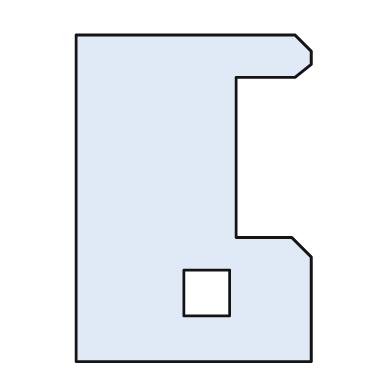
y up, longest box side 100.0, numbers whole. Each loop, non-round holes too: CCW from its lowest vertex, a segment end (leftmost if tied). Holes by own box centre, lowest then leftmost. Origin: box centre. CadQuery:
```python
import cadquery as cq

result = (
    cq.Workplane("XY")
    .moveTo(-36.0, -50.0)
    .lineTo(36.0, -50.0)
    .lineTo(36.0, -18.0)
    .lineTo(30.0, -12.0)
    .lineTo(13.0, -12.0)
    .lineTo(13.0, 37.0)
    .lineTo(31.0, 37.0)
    .lineTo(36.0, 41.0)
    .lineTo(36.0, 45.0)
    .lineTo(31.0, 50.0)
    .lineTo(-36.0, 50.0)
    .close()
    .moveTo(-3.0, -36.0)
    .lineTo(11.0, -36.0)
    .lineTo(11.0, -22.0)
    .lineTo(-3.0, -22.0)
    .close()
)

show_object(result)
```